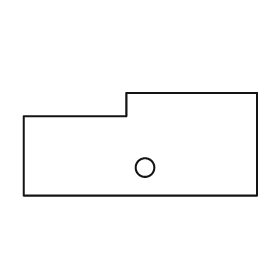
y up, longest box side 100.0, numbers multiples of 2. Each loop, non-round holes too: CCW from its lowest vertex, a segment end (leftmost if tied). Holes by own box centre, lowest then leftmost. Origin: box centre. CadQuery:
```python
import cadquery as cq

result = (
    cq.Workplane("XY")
    .moveTo(-50.0, -22.0)
    .lineTo(50.0, -22.0)
    .lineTo(50.0, 22.0)
    .lineTo(-6.0, 22.0)
    .lineTo(-6.0, 12.0)
    .lineTo(-50.0, 12.0)
    .close()
    .moveTo(2.0, -10.0)
    .circle(4.0)
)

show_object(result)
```